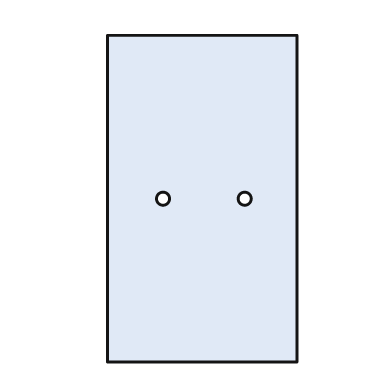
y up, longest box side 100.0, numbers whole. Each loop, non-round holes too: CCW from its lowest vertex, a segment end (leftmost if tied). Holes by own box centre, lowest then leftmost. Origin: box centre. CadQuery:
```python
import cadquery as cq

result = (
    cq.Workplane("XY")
    .moveTo(-29.0, -50.0)
    .lineTo(29.0, -50.0)
    .lineTo(29.0, 50.0)
    .lineTo(-29.0, 50.0)
    .close()
    .moveTo(-12.0, 0.0)
    .circle(2.0)
    .moveTo(13.0, 0.0)
    .circle(2.0)
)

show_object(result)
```